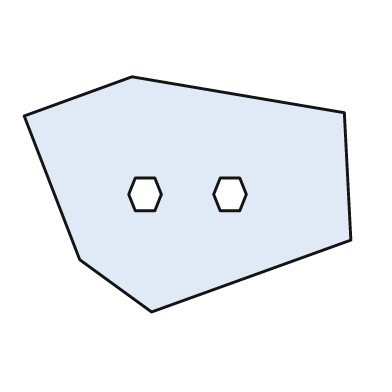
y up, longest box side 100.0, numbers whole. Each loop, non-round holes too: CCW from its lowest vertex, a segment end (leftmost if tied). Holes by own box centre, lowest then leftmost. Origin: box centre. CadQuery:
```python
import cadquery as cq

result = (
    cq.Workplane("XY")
    .moveTo(-11.0, -36.0)
    .lineTo(50.0, -14.0)
    .lineTo(48.0, 25.0)
    .lineTo(-17.0, 36.0)
    .lineTo(-50.0, 24.0)
    .lineTo(-33.0, -20.0)
    .close()
    .moveTo(-16.0, -5.0)
    .lineTo(-10.0, -5.0)
    .lineTo(-8.0, 0.0)
    .lineTo(-10.0, 5.0)
    .lineTo(-16.0, 5.0)
    .lineTo(-18.0, 0.0)
    .close()
    .moveTo(10.0, -5.0)
    .lineTo(16.0, -5.0)
    .lineTo(18.0, 0.0)
    .lineTo(16.0, 5.0)
    .lineTo(10.0, 5.0)
    .lineTo(8.0, 0.0)
    .close()
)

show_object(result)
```